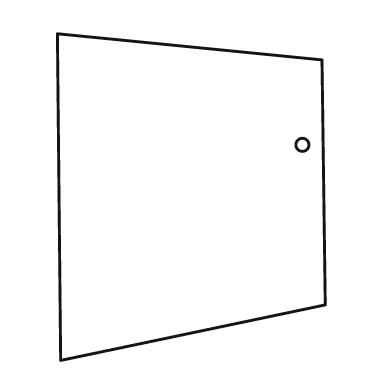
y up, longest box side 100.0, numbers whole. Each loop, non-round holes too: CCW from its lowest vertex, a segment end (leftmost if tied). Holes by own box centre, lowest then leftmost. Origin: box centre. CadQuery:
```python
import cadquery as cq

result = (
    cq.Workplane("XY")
    .moveTo(-40.0, -50.0)
    .lineTo(41.0, -33.0)
    .lineTo(40.0, 42.0)
    .lineTo(-41.0, 50.0)
    .close()
    .moveTo(34.0, 16.0)
    .circle(2.0)
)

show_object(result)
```